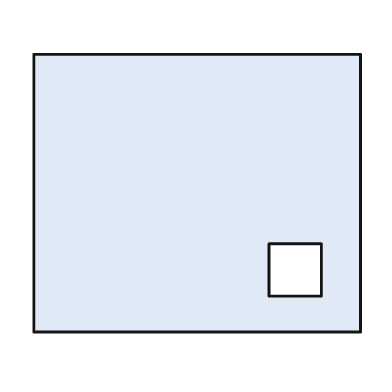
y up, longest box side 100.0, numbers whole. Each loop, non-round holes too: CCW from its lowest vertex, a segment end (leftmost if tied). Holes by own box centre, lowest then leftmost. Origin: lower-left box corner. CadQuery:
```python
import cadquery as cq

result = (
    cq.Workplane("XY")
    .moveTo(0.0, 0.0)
    .lineTo(100.0, 0.0)
    .lineTo(100.0, 85.0)
    .lineTo(0.0, 85.0)
    .close()
    .moveTo(72.0, 11.0)
    .lineTo(88.0, 11.0)
    .lineTo(88.0, 27.0)
    .lineTo(72.0, 27.0)
    .close()
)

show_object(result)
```